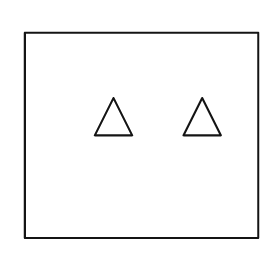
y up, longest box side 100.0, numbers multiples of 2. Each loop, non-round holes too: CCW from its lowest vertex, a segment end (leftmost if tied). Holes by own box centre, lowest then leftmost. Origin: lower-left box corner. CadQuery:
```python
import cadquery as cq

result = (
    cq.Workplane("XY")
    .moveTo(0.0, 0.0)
    .lineTo(100.0, 0.0)
    .lineTo(100.0, 88.0)
    .lineTo(0.0, 88.0)
    .close()
    .moveTo(30.0, 44.0)
    .lineTo(46.0, 44.0)
    .lineTo(38.0, 60.0)
    .close()
    .moveTo(68.0, 44.0)
    .lineTo(84.0, 44.0)
    .lineTo(76.0, 60.0)
    .close()
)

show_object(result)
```